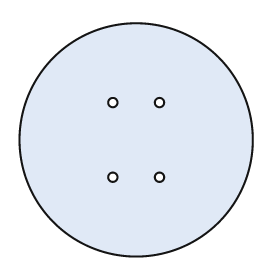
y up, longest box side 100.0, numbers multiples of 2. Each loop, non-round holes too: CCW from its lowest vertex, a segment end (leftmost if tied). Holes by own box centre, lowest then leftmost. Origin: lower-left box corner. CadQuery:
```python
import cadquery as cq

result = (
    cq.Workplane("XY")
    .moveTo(50.0, 50.0)
    .circle(50.0)
    .moveTo(40.0, 34.0)
    .circle(2.0)
    .moveTo(60.0, 34.0)
    .circle(2.0)
    .moveTo(40.0, 66.0)
    .circle(2.0)
    .moveTo(60.0, 66.0)
    .circle(2.0)
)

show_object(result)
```